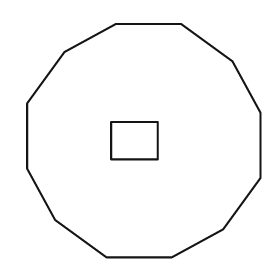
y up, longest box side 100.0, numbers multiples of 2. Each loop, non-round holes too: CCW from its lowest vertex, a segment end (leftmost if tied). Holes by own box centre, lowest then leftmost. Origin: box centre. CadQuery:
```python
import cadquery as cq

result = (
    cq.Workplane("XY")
    .moveTo(-16.0, -50.0)
    .lineTo(12.0, -50.0)
    .lineTo(34.0, -38.0)
    .lineTo(50.0, -16.0)
    .lineTo(50.0, 12.0)
    .lineTo(38.0, 34.0)
    .lineTo(16.0, 50.0)
    .lineTo(-12.0, 50.0)
    .lineTo(-34.0, 38.0)
    .lineTo(-50.0, 16.0)
    .lineTo(-50.0, -12.0)
    .lineTo(-38.0, -34.0)
    .close()
    .moveTo(-14.0, -8.0)
    .lineTo(6.0, -8.0)
    .lineTo(6.0, 8.0)
    .lineTo(-14.0, 8.0)
    .close()
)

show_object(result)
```